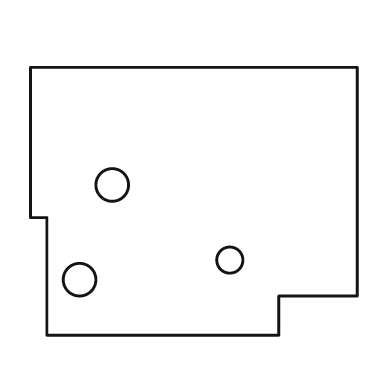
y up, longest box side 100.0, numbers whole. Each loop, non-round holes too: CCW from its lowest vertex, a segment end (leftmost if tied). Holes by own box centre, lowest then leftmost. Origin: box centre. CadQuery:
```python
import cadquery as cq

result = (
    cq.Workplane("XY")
    .moveTo(-45.0, -41.0)
    .lineTo(26.0, -41.0)
    .lineTo(26.0, -29.0)
    .lineTo(50.0, -29.0)
    .lineTo(50.0, 41.0)
    .lineTo(-50.0, 41.0)
    .lineTo(-50.0, -5.0)
    .lineTo(-45.0, -5.0)
    .close()
    .moveTo(-35.0, -24.0)
    .circle(5.0)
    .moveTo(11.0, -18.0)
    .circle(4.0)
    .moveTo(-25.0, 5.0)
    .circle(5.0)
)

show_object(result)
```